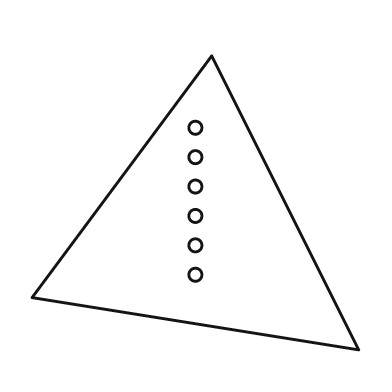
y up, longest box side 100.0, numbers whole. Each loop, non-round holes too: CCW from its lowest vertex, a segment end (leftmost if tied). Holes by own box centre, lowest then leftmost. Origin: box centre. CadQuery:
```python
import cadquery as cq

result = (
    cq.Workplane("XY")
    .moveTo(50.0, -45.0)
    .lineTo(5.0, 45.0)
    .lineTo(-50.0, -29.0)
    .close()
    .moveTo(0.0, -22.0)
    .circle(2.0)
    .moveTo(0.0, -13.0)
    .circle(2.0)
    .moveTo(0.0, -4.0)
    .circle(2.0)
    .moveTo(0.0, 5.0)
    .circle(2.0)
    .moveTo(0.0, 14.0)
    .circle(2.0)
    .moveTo(0.0, 23.0)
    .circle(2.0)
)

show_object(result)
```